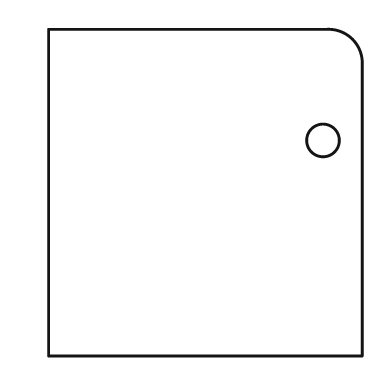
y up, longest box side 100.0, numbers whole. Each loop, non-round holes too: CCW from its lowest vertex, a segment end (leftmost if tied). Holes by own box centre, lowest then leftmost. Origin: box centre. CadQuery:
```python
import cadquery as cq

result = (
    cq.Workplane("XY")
    .moveTo(-48.0, -50.0)
    .lineTo(48.0, -50.0)
    .lineTo(48.0, 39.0)
    .threePointArc((45.0, 47.0), (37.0, 50.0))
    .lineTo(-48.0, 50.0)
    .close()
    .moveTo(36.0, 16.0)
    .circle(5.0)
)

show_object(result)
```